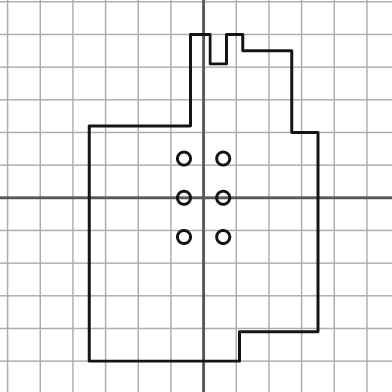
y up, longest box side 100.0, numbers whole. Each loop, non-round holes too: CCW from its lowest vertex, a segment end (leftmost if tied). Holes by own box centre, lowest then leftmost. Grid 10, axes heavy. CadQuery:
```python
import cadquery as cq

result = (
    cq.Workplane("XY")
    .moveTo(-35.0, -50.0)
    .lineTo(11.0, -50.0)
    .lineTo(11.0, -41.0)
    .lineTo(35.0, -41.0)
    .lineTo(35.0, 20.0)
    .lineTo(27.0, 20.0)
    .lineTo(27.0, 45.0)
    .lineTo(12.0, 45.0)
    .lineTo(12.0, 50.0)
    .lineTo(7.0, 50.0)
    .lineTo(7.0, 41.0)
    .lineTo(2.0, 41.0)
    .lineTo(2.0, 50.0)
    .lineTo(-4.0, 50.0)
    .lineTo(-4.0, 22.0)
    .lineTo(-35.0, 22.0)
    .close()
    .moveTo(-6.0, -12.0)
    .circle(2.0)
    .moveTo(6.0, -12.0)
    .circle(2.0)
    .moveTo(-6.0, 0.0)
    .circle(2.0)
    .moveTo(6.0, 0.0)
    .circle(2.0)
    .moveTo(-6.0, 12.0)
    .circle(2.0)
    .moveTo(6.0, 12.0)
    .circle(2.0)
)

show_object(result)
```